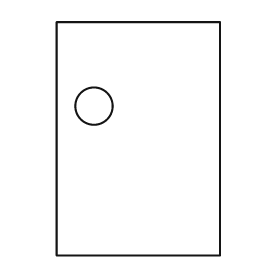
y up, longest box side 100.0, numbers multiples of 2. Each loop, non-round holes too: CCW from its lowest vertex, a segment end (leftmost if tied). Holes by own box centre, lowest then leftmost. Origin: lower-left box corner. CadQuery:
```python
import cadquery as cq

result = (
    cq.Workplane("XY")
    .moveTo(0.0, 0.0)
    .lineTo(70.0, 0.0)
    .lineTo(70.0, 100.0)
    .lineTo(0.0, 100.0)
    .close()
    .moveTo(16.0, 64.0)
    .circle(8.0)
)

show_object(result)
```